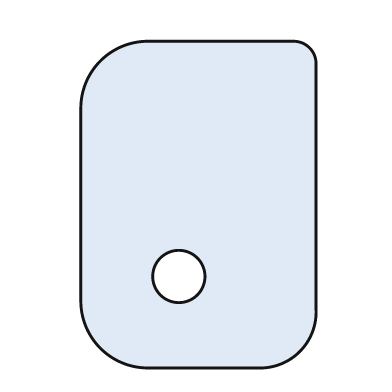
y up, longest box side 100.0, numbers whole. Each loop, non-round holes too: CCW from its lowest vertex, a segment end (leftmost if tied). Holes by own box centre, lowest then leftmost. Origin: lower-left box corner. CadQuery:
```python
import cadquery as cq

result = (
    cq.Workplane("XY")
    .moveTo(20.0, 0.0)
    .lineTo(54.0, 0.0)
    .threePointArc((67.0, 5.0), (72.0, 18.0))
    .lineTo(72.0, 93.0)
    .threePointArc((70.0, 98.0), (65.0, 100.0))
    .lineTo(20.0, 100.0)
    .threePointArc((6.0, 94.0), (0.0, 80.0))
    .lineTo(0.0, 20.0)
    .threePointArc((6.0, 6.0), (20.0, 0.0))
    .close()
    .moveTo(30.0, 28.0)
    .circle(8.0)
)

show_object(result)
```